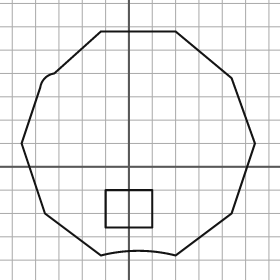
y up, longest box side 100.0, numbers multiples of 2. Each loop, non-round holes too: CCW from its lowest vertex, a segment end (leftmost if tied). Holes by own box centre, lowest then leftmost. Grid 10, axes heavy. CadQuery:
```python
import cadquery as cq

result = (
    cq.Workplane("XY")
    .moveTo(-12.0, -38.0)
    .threePointArc((4.0, -36.0), (20.0, -38.0))
    .lineTo(44.0, -20.0)
    .lineTo(54.0, 10.0)
    .lineTo(44.0, 38.0)
    .lineTo(20.0, 58.0)
    .lineTo(-12.0, 58.0)
    .lineTo(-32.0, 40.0)
    .threePointArc((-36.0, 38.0), (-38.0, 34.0))
    .lineTo(-46.0, 10.0)
    .lineTo(-36.0, -20.0)
    .close()
    .moveTo(-10.0, -26.0)
    .lineTo(10.0, -26.0)
    .lineTo(10.0, -10.0)
    .lineTo(-10.0, -10.0)
    .close()
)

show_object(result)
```